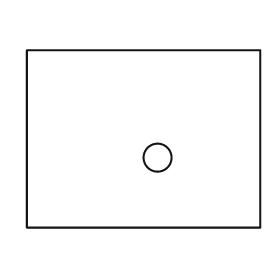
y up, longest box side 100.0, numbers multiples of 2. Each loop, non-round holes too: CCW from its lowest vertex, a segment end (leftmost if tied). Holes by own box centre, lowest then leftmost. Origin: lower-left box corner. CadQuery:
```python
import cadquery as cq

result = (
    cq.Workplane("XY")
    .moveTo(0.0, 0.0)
    .lineTo(100.0, 0.0)
    .lineTo(100.0, 76.0)
    .lineTo(0.0, 76.0)
    .close()
    .moveTo(56.0, 30.0)
    .circle(6.0)
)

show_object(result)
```